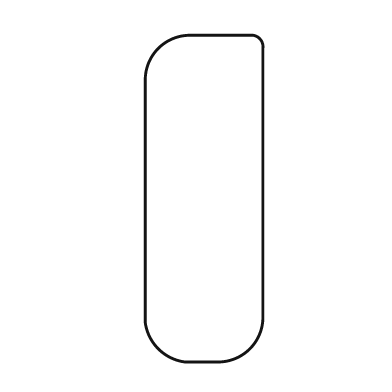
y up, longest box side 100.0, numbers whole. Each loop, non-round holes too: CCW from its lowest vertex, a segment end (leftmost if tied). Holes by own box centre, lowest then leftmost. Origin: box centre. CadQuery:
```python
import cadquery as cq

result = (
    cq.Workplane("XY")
    .moveTo(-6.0, -50.0)
    .lineTo(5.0, -50.0)
    .threePointArc((14.0, -46.0), (18.0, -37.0))
    .lineTo(18.0, 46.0)
    .threePointArc((17.0, 49.0), (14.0, 50.0))
    .lineTo(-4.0, 50.0)
    .threePointArc((-14.0, 46.0), (-18.0, 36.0))
    .lineTo(-18.0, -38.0)
    .threePointArc((-14.0, -46.0), (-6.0, -50.0))
    .close()
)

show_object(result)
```